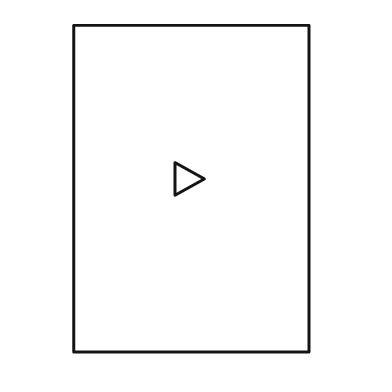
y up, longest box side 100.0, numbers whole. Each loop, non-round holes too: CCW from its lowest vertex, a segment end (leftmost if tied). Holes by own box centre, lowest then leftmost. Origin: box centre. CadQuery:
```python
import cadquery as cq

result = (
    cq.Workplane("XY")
    .moveTo(-36.0, -50.0)
    .lineTo(36.0, -50.0)
    .lineTo(36.0, 50.0)
    .lineTo(-36.0, 50.0)
    .close()
    .moveTo(-5.0, -2.0)
    .lineTo(4.0, 3.0)
    .lineTo(-5.0, 8.0)
    .close()
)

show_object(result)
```